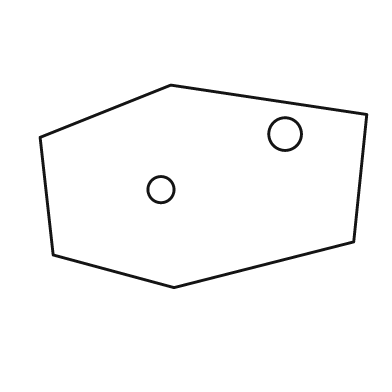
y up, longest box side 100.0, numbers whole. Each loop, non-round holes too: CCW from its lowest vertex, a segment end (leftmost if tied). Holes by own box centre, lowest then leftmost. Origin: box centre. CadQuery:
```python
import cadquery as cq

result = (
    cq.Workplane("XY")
    .moveTo(-9.0, -31.0)
    .lineTo(46.0, -17.0)
    .lineTo(50.0, 22.0)
    .lineTo(-10.0, 31.0)
    .lineTo(-50.0, 15.0)
    .lineTo(-46.0, -21.0)
    .close()
    .moveTo(-13.0, -1.0)
    .circle(4.0)
    .moveTo(25.0, 16.0)
    .circle(5.0)
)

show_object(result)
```